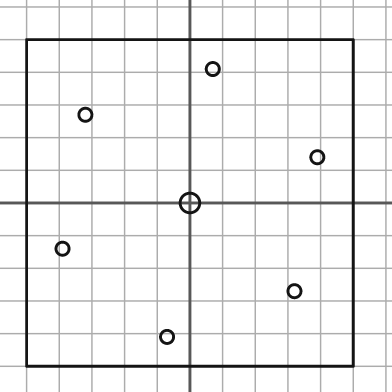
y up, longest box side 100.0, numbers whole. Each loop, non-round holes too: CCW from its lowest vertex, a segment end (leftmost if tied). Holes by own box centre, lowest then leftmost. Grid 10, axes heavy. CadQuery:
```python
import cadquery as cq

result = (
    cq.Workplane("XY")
    .moveTo(-50.0, -50.0)
    .lineTo(50.0, -50.0)
    .lineTo(50.0, 50.0)
    .lineTo(-50.0, 50.0)
    .close()
    .moveTo(-7.0, -41.0)
    .circle(2.0)
    .moveTo(32.0, -27.0)
    .circle(2.0)
    .moveTo(-39.0, -14.0)
    .circle(2.0)
    .moveTo(0.0, 0.0)
    .circle(3.0)
    .moveTo(39.0, 14.0)
    .circle(2.0)
    .moveTo(-32.0, 27.0)
    .circle(2.0)
    .moveTo(7.0, 41.0)
    .circle(2.0)
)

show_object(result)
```